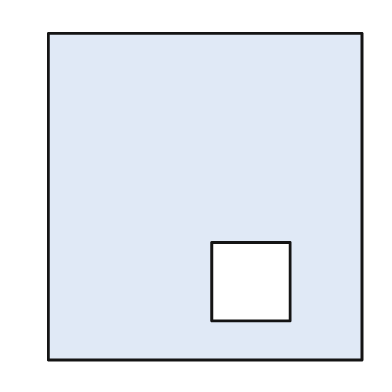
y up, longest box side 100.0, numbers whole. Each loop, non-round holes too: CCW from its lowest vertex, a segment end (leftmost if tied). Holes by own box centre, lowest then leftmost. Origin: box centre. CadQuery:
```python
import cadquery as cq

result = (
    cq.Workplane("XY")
    .moveTo(-48.0, -50.0)
    .lineTo(48.0, -50.0)
    .lineTo(48.0, 50.0)
    .lineTo(-48.0, 50.0)
    .close()
    .moveTo(2.0, -38.0)
    .lineTo(26.0, -38.0)
    .lineTo(26.0, -14.0)
    .lineTo(2.0, -14.0)
    .close()
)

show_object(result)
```